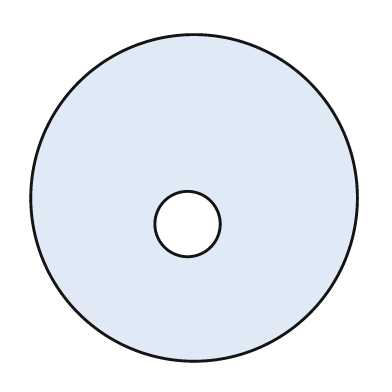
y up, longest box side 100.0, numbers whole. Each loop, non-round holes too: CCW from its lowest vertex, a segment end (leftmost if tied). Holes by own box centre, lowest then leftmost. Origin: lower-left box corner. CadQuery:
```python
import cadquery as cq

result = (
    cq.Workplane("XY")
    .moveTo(50.0, 50.0)
    .circle(50.0)
    .moveTo(48.0, 42.0)
    .circle(10.0)
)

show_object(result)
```